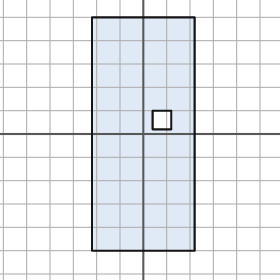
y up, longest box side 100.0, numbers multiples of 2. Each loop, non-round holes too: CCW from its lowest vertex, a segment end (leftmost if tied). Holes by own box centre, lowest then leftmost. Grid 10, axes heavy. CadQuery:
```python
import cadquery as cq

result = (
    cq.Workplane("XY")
    .moveTo(-22.0, -50.0)
    .lineTo(22.0, -50.0)
    .lineTo(22.0, 50.0)
    .lineTo(-22.0, 50.0)
    .close()
    .moveTo(4.0, 2.0)
    .lineTo(12.0, 2.0)
    .lineTo(12.0, 10.0)
    .lineTo(4.0, 10.0)
    .close()
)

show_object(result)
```